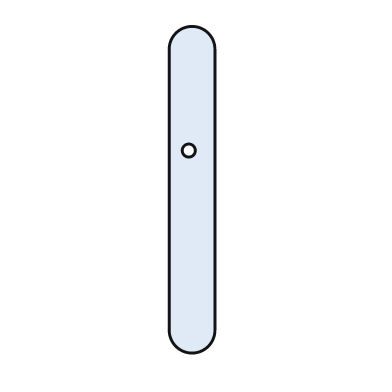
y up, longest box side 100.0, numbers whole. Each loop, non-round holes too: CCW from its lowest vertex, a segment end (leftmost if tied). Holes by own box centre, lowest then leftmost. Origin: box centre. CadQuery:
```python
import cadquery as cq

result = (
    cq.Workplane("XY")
    .moveTo(-7.0, -43.0)
    .threePointArc((0.0, -50.0), (7.0, -43.0))
    .lineTo(7.0, 43.0)
    .threePointArc((0.0, 50.0), (-7.0, 43.0))
    .close()
    .moveTo(-1.0, 12.0)
    .circle(2.0)
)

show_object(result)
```